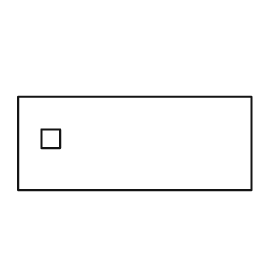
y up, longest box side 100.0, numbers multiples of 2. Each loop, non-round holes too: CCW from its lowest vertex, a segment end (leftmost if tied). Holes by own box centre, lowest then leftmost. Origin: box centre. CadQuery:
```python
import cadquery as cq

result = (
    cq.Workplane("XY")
    .moveTo(-50.0, -20.0)
    .lineTo(50.0, -20.0)
    .lineTo(50.0, 20.0)
    .lineTo(-50.0, 20.0)
    .close()
    .moveTo(-40.0, -2.0)
    .lineTo(-32.0, -2.0)
    .lineTo(-32.0, 6.0)
    .lineTo(-40.0, 6.0)
    .close()
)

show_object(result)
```